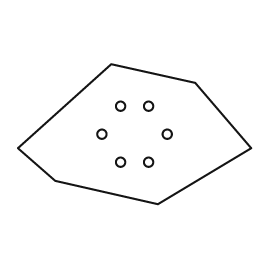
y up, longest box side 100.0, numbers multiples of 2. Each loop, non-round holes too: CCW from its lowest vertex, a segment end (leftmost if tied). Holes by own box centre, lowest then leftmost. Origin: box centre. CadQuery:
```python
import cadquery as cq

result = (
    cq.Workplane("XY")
    .moveTo(10.0, -30.0)
    .lineTo(50.0, -6.0)
    .lineTo(26.0, 22.0)
    .lineTo(-10.0, 30.0)
    .lineTo(-50.0, -6.0)
    .lineTo(-34.0, -20.0)
    .close()
    .moveTo(-6.0, -12.0)
    .circle(2.0)
    .moveTo(6.0, -12.0)
    .circle(2.0)
    .moveTo(-14.0, 0.0)
    .circle(2.0)
    .moveTo(14.0, 0.0)
    .circle(2.0)
    .moveTo(-6.0, 12.0)
    .circle(2.0)
    .moveTo(6.0, 12.0)
    .circle(2.0)
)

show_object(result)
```